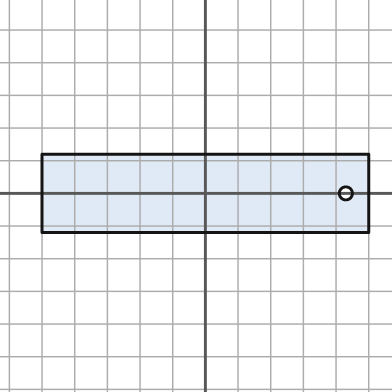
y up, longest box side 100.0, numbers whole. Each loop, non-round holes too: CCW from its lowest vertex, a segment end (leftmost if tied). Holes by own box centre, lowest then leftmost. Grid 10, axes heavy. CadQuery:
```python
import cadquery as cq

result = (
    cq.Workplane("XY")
    .moveTo(-50.0, -12.0)
    .lineTo(50.0, -12.0)
    .lineTo(50.0, 12.0)
    .lineTo(-50.0, 12.0)
    .close()
    .moveTo(43.0, 0.0)
    .circle(2.0)
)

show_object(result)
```